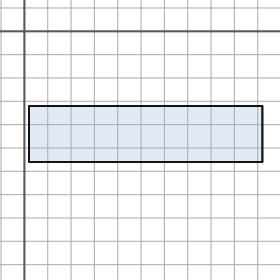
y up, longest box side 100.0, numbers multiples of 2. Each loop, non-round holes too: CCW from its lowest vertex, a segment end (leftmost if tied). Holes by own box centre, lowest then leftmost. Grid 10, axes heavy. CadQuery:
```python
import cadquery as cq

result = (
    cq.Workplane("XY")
    .moveTo(2.0, -56.0)
    .lineTo(102.0, -56.0)
    .lineTo(102.0, -32.0)
    .lineTo(2.0, -32.0)
    .close()
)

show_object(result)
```